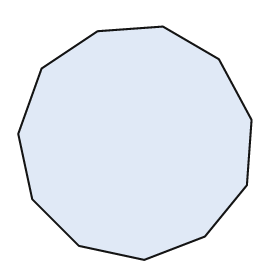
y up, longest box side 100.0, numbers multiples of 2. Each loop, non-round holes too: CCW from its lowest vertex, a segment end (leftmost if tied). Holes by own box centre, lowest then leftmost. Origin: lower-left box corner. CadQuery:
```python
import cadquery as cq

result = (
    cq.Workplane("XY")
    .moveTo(54.0, 0.0)
    .lineTo(80.0, 10.0)
    .lineTo(98.0, 32.0)
    .lineTo(100.0, 60.0)
    .lineTo(86.0, 86.0)
    .lineTo(62.0, 100.0)
    .lineTo(34.0, 98.0)
    .lineTo(10.0, 82.0)
    .lineTo(0.0, 54.0)
    .lineTo(6.0, 26.0)
    .lineTo(26.0, 6.0)
    .close()
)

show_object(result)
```